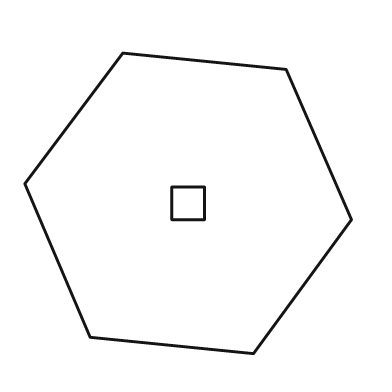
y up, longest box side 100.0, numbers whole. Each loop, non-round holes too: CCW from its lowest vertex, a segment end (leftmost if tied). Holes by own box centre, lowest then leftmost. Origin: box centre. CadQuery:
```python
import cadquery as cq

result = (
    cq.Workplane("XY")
    .moveTo(20.0, -46.0)
    .lineTo(50.0, -5.0)
    .lineTo(30.0, 41.0)
    .lineTo(-20.0, 46.0)
    .lineTo(-50.0, 6.0)
    .lineTo(-30.0, -41.0)
    .close()
    .moveTo(-5.0, -5.0)
    .lineTo(5.0, -5.0)
    .lineTo(5.0, 5.0)
    .lineTo(-5.0, 5.0)
    .close()
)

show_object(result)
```